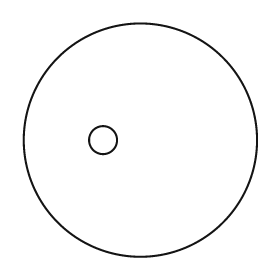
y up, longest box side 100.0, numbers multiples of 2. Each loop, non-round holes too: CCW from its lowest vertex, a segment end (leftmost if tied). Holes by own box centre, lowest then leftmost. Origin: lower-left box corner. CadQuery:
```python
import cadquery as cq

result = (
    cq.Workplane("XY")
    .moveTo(50.0, 50.0)
    .circle(50.0)
    .moveTo(34.0, 50.0)
    .circle(6.0)
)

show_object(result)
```